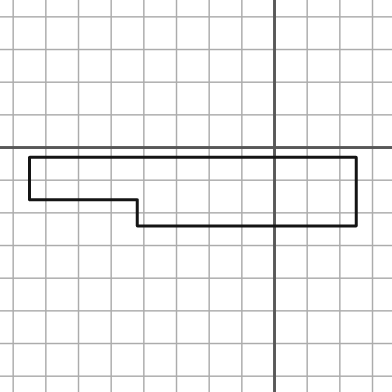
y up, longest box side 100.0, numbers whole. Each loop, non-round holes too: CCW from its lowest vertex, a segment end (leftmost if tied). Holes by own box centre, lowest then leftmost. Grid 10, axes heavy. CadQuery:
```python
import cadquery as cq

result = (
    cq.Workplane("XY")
    .moveTo(-42.0, -24.0)
    .lineTo(25.0, -24.0)
    .lineTo(25.0, -3.0)
    .lineTo(-75.0, -3.0)
    .lineTo(-75.0, -16.0)
    .lineTo(-42.0, -16.0)
    .close()
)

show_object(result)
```